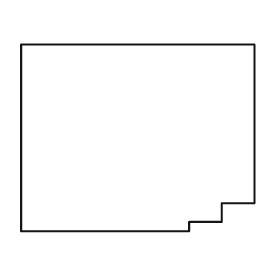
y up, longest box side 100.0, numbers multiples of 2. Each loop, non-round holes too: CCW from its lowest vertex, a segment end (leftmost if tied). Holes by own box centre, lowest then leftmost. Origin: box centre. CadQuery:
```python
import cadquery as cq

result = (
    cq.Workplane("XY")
    .moveTo(-50.0, -40.0)
    .lineTo(22.0, -40.0)
    .lineTo(22.0, -36.0)
    .lineTo(36.0, -36.0)
    .lineTo(36.0, -28.0)
    .lineTo(50.0, -28.0)
    .lineTo(50.0, 40.0)
    .lineTo(-50.0, 40.0)
    .close()
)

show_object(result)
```